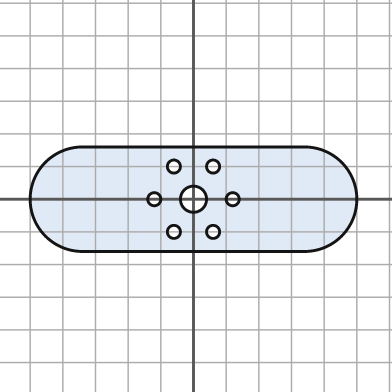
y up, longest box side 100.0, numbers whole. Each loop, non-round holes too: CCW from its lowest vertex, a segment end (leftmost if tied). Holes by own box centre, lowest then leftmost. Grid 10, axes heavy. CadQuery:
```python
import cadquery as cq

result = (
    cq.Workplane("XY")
    .moveTo(-34.0, -16.0)
    .lineTo(34.0, -16.0)
    .threePointArc((50.0, 0.0), (34.0, 16.0))
    .lineTo(-34.0, 16.0)
    .threePointArc((-50.0, 0.0), (-34.0, -16.0))
    .close()
    .moveTo(-6.0, -10.0)
    .circle(2.0)
    .moveTo(6.0, -10.0)
    .circle(2.0)
    .moveTo(-12.0, 0.0)
    .circle(2.0)
    .moveTo(0.0, 0.0)
    .circle(4.0)
    .moveTo(12.0, 0.0)
    .circle(2.0)
    .moveTo(-6.0, 10.0)
    .circle(2.0)
    .moveTo(6.0, 10.0)
    .circle(2.0)
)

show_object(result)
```